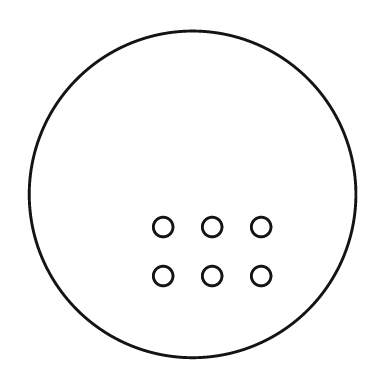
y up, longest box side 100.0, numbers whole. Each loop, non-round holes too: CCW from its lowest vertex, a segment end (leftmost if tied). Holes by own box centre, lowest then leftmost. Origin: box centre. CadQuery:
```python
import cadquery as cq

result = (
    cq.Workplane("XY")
    .moveTo(0.0, 0.0)
    .circle(50.0)
    .moveTo(-9.0, -25.0)
    .circle(3.0)
    .moveTo(6.0, -25.0)
    .circle(3.0)
    .moveTo(21.0, -25.0)
    .circle(3.0)
    .moveTo(-9.0, -10.0)
    .circle(3.0)
    .moveTo(6.0, -10.0)
    .circle(3.0)
    .moveTo(21.0, -10.0)
    .circle(3.0)
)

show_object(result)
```